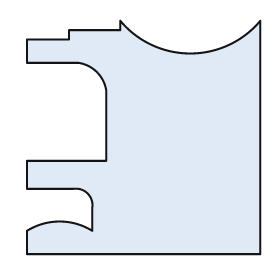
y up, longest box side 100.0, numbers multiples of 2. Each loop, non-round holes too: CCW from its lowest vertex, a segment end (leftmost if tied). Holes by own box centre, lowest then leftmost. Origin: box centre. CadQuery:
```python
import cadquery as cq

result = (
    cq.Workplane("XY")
    .moveTo(-50.0, -50.0)
    .lineTo(50.0, -50.0)
    .lineTo(50.0, 50.0)
    .threePointArc((20.0, 36.0), (-10.0, 50.0))
    .lineTo(-10.0, 46.0)
    .lineTo(-32.0, 46.0)
    .lineTo(-32.0, 42.0)
    .lineTo(-50.0, 42.0)
    .lineTo(-50.0, 32.0)
    .lineTo(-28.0, 32.0)
    .threePointArc((-20.0, 28.0), (-16.0, 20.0))
    .lineTo(-16.0, -10.0)
    .lineTo(-50.0, -10.0)
    .lineTo(-50.0, -22.0)
    .lineTo(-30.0, -22.0)
    .threePointArc((-24.0, -24.0), (-22.0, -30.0))
    .lineTo(-22.0, -40.0)
    .threePointArc((-36.0, -36.0), (-50.0, -40.0))
    .close()
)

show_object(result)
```